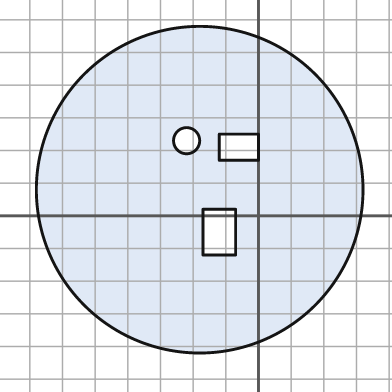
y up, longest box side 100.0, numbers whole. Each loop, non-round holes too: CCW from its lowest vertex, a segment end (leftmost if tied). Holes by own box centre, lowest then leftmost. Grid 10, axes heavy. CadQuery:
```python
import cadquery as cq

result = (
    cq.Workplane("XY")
    .moveTo(-18.0, 8.0)
    .circle(50.0)
    .moveTo(-17.0, -12.0)
    .lineTo(-7.0, -12.0)
    .lineTo(-7.0, 2.0)
    .lineTo(-17.0, 2.0)
    .close()
    .moveTo(-12.0, 17.0)
    .lineTo(0.0, 17.0)
    .lineTo(0.0, 25.0)
    .lineTo(-12.0, 25.0)
    .close()
    .moveTo(-22.0, 23.0)
    .circle(4.0)
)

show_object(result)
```